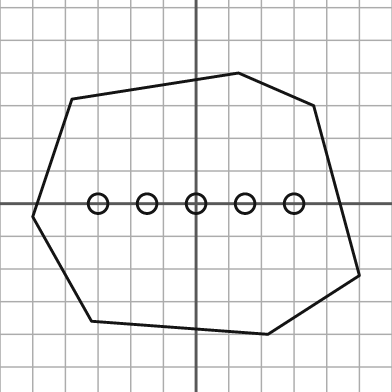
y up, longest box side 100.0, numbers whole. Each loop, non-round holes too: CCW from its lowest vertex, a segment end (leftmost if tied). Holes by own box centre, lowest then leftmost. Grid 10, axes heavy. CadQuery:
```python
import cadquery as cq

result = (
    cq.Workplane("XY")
    .moveTo(22.0, -40.0)
    .lineTo(50.0, -22.0)
    .lineTo(36.0, 30.0)
    .lineTo(13.0, 40.0)
    .lineTo(-38.0, 32.0)
    .lineTo(-50.0, -4.0)
    .lineTo(-32.0, -36.0)
    .close()
    .moveTo(-30.0, 0.0)
    .circle(3.0)
    .moveTo(-15.0, 0.0)
    .circle(3.0)
    .moveTo(0.0, 0.0)
    .circle(3.0)
    .moveTo(15.0, 0.0)
    .circle(3.0)
    .moveTo(30.0, 0.0)
    .circle(3.0)
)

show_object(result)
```